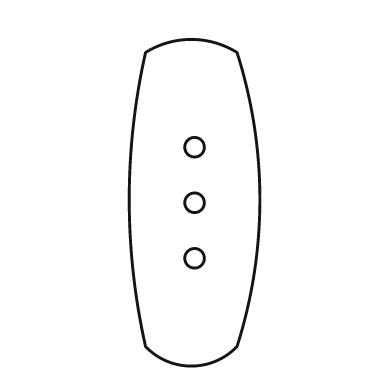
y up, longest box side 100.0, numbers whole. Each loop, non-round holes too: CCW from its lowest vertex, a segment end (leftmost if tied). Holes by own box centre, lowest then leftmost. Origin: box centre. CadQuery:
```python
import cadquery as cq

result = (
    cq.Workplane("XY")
    .moveTo(-15.0, -44.0)
    .threePointArc((-1.0, -50.0), (13.0, -44.0))
    .threePointArc((20.0, 1.0), (13.0, 46.0))
    .threePointArc((-1.0, 50.0), (-15.0, 46.0))
    .threePointArc((-20.0, 1.0), (-15.0, -44.0))
    .close()
    .moveTo(0.0, -17.0)
    .circle(3.0)
    .moveTo(0.0, 0.0)
    .circle(3.0)
    .moveTo(0.0, 17.0)
    .circle(3.0)
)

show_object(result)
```